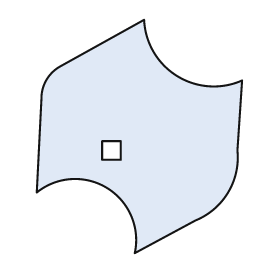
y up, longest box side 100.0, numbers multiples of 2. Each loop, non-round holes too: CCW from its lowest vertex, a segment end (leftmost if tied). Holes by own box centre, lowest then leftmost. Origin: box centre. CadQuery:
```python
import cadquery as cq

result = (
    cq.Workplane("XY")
    .moveTo(-2.0, -50.0)
    .lineTo(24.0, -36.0)
    .threePointArc((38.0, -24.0), (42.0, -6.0))
    .lineTo(44.0, 24.0)
    .threePointArc((16.0, 26.0), (2.0, 50.0))
    .lineTo(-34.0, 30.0)
    .threePointArc((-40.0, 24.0), (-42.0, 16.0))
    .lineTo(-44.0, -24.0)
    .threePointArc((-14.0, -22.0), (-2.0, -50.0))
    .close()
    .moveTo(-16.0, -10.0)
    .lineTo(-8.0, -10.0)
    .lineTo(-8.0, -2.0)
    .lineTo(-16.0, -2.0)
    .close()
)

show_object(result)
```